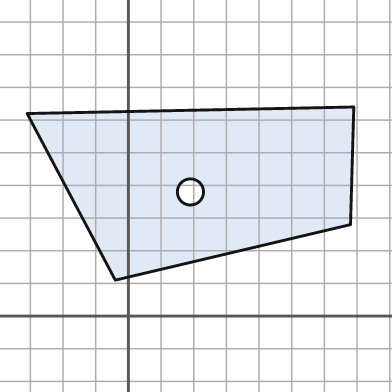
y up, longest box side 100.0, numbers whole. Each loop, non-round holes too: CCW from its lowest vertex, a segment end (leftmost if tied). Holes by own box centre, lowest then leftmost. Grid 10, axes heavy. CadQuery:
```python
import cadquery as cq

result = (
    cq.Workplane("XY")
    .moveTo(-4.0, 11.0)
    .lineTo(68.0, 28.0)
    .lineTo(69.0, 64.0)
    .lineTo(-31.0, 62.0)
    .close()
    .moveTo(19.0, 38.0)
    .circle(4.0)
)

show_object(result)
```